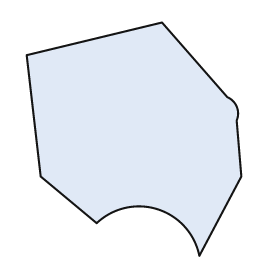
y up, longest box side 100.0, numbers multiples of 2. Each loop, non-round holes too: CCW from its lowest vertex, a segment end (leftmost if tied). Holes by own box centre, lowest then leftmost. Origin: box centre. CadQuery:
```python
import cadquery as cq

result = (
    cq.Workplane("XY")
    .moveTo(28.0, -50.0)
    .lineTo(46.0, -16.0)
    .lineTo(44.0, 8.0)
    .threePointArc((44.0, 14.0), (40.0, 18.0))
    .lineTo(12.0, 50.0)
    .lineTo(-46.0, 36.0)
    .lineTo(-40.0, -16.0)
    .lineTo(-16.0, -36.0)
    .threePointArc((10.0, -30.0), (28.0, -50.0))
    .close()
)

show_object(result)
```